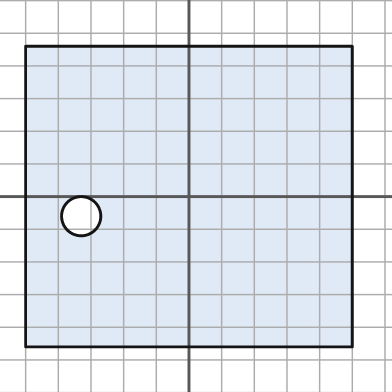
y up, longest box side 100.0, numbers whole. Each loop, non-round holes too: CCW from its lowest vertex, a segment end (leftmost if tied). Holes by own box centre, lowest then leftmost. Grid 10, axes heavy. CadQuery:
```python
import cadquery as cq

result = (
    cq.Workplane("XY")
    .moveTo(-50.0, -46.0)
    .lineTo(50.0, -46.0)
    .lineTo(50.0, 46.0)
    .lineTo(-50.0, 46.0)
    .close()
    .moveTo(-33.0, -6.0)
    .circle(6.0)
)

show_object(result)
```